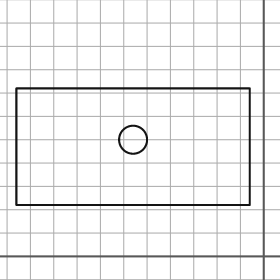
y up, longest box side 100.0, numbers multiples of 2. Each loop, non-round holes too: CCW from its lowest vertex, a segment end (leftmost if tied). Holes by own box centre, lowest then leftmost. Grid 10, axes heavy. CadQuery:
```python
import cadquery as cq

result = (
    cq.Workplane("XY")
    .moveTo(-106.0, 22.0)
    .lineTo(-6.0, 22.0)
    .lineTo(-6.0, 72.0)
    .lineTo(-106.0, 72.0)
    .close()
    .moveTo(-56.0, 50.0)
    .circle(6.0)
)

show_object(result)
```